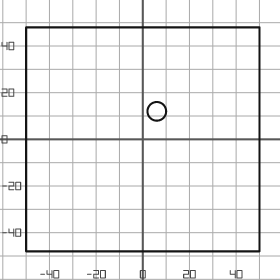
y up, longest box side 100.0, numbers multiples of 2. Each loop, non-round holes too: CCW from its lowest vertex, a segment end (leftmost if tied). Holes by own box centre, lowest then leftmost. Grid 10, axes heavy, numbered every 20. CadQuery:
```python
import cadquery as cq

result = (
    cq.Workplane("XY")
    .moveTo(-50.0, -48.0)
    .lineTo(50.0, -48.0)
    .lineTo(50.0, 48.0)
    .lineTo(-50.0, 48.0)
    .close()
    .moveTo(6.0, 12.0)
    .circle(4.0)
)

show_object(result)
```